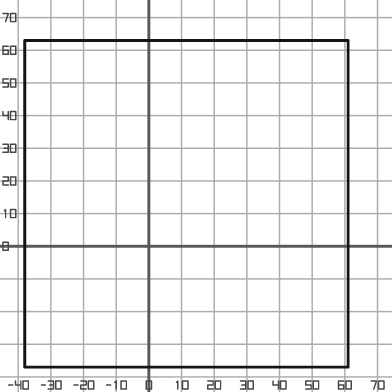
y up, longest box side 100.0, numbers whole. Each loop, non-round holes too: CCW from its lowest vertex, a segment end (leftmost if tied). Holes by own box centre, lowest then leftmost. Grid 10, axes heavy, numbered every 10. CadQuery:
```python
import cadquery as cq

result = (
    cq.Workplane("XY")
    .moveTo(-38.0, -37.0)
    .lineTo(61.0, -37.0)
    .lineTo(61.0, 63.0)
    .lineTo(-38.0, 63.0)
    .close()
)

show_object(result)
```